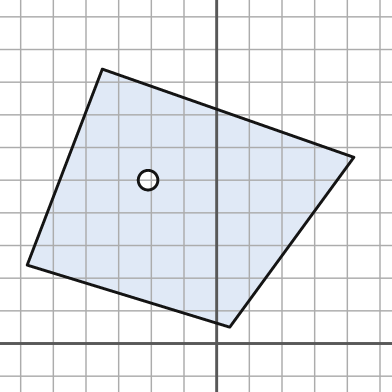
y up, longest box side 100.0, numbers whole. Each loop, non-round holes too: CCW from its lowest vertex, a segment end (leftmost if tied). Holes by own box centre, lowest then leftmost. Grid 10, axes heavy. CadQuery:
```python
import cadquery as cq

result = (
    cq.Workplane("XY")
    .moveTo(4.0, 5.0)
    .lineTo(42.0, 57.0)
    .lineTo(-35.0, 84.0)
    .lineTo(-58.0, 24.0)
    .close()
    .moveTo(-21.0, 50.0)
    .circle(3.0)
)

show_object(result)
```